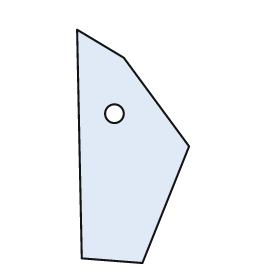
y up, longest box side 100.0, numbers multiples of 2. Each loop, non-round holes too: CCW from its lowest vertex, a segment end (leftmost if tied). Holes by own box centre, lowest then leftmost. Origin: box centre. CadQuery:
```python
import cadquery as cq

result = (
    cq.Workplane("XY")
    .moveTo(4.0, -50.0)
    .lineTo(24.0, 0.0)
    .lineTo(-4.0, 38.0)
    .lineTo(-24.0, 50.0)
    .lineTo(-22.0, -48.0)
    .close()
    .moveTo(-8.0, 14.0)
    .circle(4.0)
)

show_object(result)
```